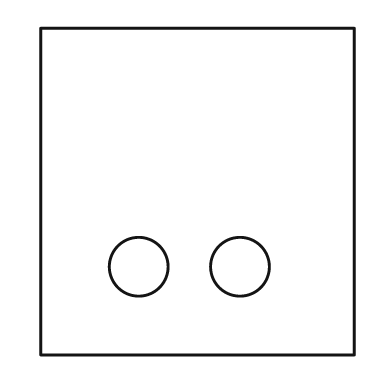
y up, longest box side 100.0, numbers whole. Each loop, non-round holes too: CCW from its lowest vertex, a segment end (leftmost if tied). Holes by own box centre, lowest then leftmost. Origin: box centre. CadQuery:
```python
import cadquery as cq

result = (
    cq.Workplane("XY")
    .moveTo(-48.0, -50.0)
    .lineTo(48.0, -50.0)
    .lineTo(48.0, 50.0)
    .lineTo(-48.0, 50.0)
    .close()
    .moveTo(-18.0, -23.0)
    .circle(9.0)
    .moveTo(13.0, -23.0)
    .circle(9.0)
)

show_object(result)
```